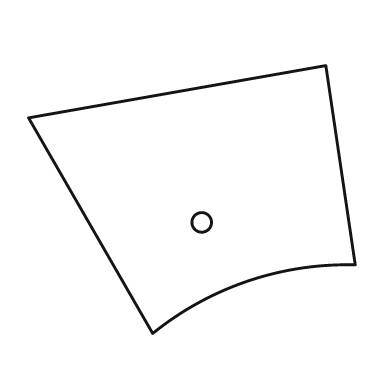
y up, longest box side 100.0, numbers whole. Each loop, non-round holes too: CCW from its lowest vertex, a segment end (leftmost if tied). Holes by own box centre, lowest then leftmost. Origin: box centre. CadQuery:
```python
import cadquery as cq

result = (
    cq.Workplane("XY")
    .moveTo(-12.0, -41.0)
    .threePointArc((17.0, -25.0), (50.0, -20.0))
    .lineTo(41.0, 41.0)
    .lineTo(-50.0, 25.0)
    .close()
    .moveTo(3.0, -7.0)
    .circle(3.0)
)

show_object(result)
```